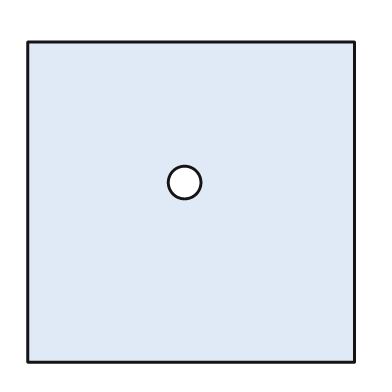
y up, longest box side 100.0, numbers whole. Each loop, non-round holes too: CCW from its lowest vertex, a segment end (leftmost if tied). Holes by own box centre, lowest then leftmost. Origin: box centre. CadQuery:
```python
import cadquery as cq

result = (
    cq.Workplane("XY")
    .moveTo(-50.0, -49.0)
    .lineTo(50.0, -49.0)
    .lineTo(50.0, 49.0)
    .lineTo(-50.0, 49.0)
    .close()
    .moveTo(-2.0, 6.0)
    .circle(5.0)
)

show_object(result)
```